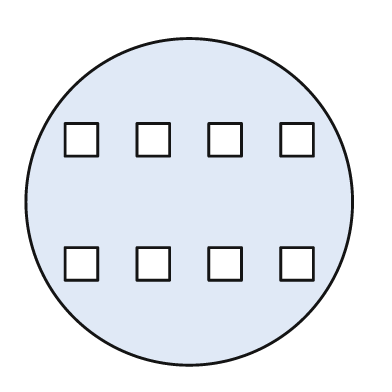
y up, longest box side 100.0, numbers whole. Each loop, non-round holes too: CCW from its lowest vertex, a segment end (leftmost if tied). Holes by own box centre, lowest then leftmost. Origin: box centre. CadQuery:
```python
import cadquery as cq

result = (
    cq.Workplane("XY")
    .moveTo(0.0, 0.0)
    .circle(50.0)
    .moveTo(-38.0, -24.0)
    .lineTo(-28.0, -24.0)
    .lineTo(-28.0, -14.0)
    .lineTo(-38.0, -14.0)
    .close()
    .moveTo(-16.0, -24.0)
    .lineTo(-6.0, -24.0)
    .lineTo(-6.0, -14.0)
    .lineTo(-16.0, -14.0)
    .close()
    .moveTo(6.0, -24.0)
    .lineTo(16.0, -24.0)
    .lineTo(16.0, -14.0)
    .lineTo(6.0, -14.0)
    .close()
    .moveTo(28.0, -24.0)
    .lineTo(38.0, -24.0)
    .lineTo(38.0, -14.0)
    .lineTo(28.0, -14.0)
    .close()
    .moveTo(-38.0, 14.0)
    .lineTo(-28.0, 14.0)
    .lineTo(-28.0, 24.0)
    .lineTo(-38.0, 24.0)
    .close()
    .moveTo(-16.0, 14.0)
    .lineTo(-6.0, 14.0)
    .lineTo(-6.0, 24.0)
    .lineTo(-16.0, 24.0)
    .close()
    .moveTo(6.0, 14.0)
    .lineTo(16.0, 14.0)
    .lineTo(16.0, 24.0)
    .lineTo(6.0, 24.0)
    .close()
    .moveTo(28.0, 14.0)
    .lineTo(38.0, 14.0)
    .lineTo(38.0, 24.0)
    .lineTo(28.0, 24.0)
    .close()
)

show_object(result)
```